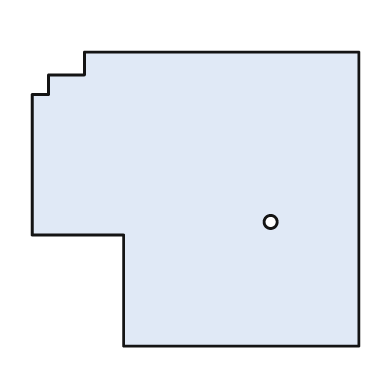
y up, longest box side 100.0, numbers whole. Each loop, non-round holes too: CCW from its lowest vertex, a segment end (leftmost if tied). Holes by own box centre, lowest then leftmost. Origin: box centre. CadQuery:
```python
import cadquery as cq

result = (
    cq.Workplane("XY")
    .moveTo(-22.0, -45.0)
    .lineTo(50.0, -45.0)
    .lineTo(50.0, 45.0)
    .lineTo(-34.0, 45.0)
    .lineTo(-34.0, 38.0)
    .lineTo(-45.0, 38.0)
    .lineTo(-45.0, 32.0)
    .lineTo(-50.0, 32.0)
    .lineTo(-50.0, -11.0)
    .lineTo(-22.0, -11.0)
    .close()
    .moveTo(23.0, -7.0)
    .circle(2.0)
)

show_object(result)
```